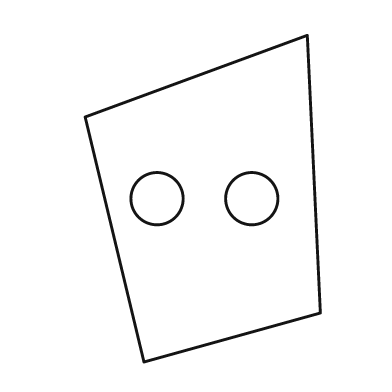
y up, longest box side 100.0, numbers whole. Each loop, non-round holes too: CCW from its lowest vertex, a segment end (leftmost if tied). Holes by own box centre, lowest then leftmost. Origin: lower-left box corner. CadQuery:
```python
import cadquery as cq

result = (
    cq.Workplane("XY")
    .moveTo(18.0, 0.0)
    .lineTo(72.0, 15.0)
    .lineTo(68.0, 100.0)
    .lineTo(0.0, 75.0)
    .close()
    .moveTo(22.0, 50.0)
    .circle(8.0)
    .moveTo(51.0, 50.0)
    .circle(8.0)
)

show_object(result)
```